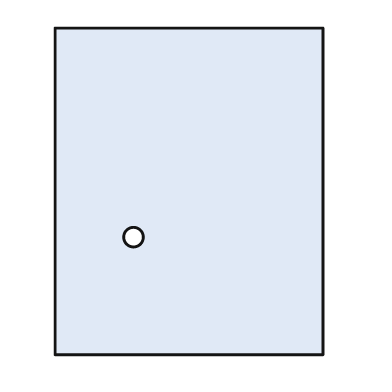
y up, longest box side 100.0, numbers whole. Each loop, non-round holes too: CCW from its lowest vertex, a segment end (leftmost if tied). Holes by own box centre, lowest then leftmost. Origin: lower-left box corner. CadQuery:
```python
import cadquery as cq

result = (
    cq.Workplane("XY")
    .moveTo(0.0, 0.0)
    .lineTo(82.0, 0.0)
    .lineTo(82.0, 100.0)
    .lineTo(0.0, 100.0)
    .close()
    .moveTo(24.0, 36.0)
    .circle(3.0)
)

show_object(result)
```